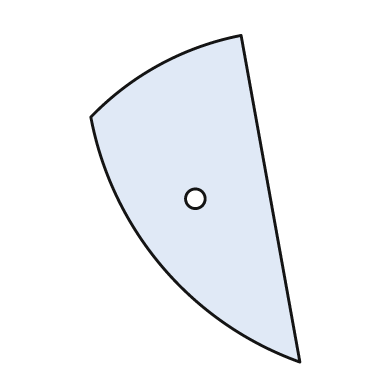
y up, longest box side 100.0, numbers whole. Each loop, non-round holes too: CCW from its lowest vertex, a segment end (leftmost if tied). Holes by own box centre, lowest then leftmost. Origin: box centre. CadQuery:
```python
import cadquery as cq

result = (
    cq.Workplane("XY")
    .moveTo(32.0, -50.0)
    .lineTo(14.0, 50.0)
    .threePointArc((-11.0, 41.0), (-32.0, 25.0))
    .threePointArc((-10.0, -21.0), (32.0, -50.0))
    .close()
    .moveTo(0.0, 0.0)
    .circle(3.0)
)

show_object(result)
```